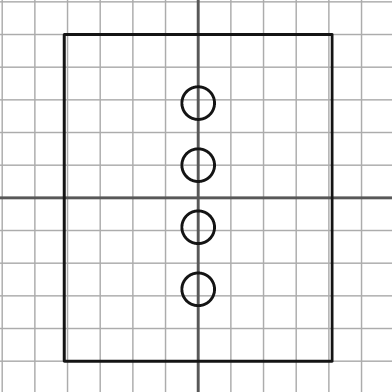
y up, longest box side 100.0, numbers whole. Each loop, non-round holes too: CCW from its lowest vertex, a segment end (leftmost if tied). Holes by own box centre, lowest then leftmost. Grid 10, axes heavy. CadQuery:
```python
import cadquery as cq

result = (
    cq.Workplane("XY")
    .moveTo(-41.0, -50.0)
    .lineTo(41.0, -50.0)
    .lineTo(41.0, 50.0)
    .lineTo(-41.0, 50.0)
    .close()
    .moveTo(0.0, -28.0)
    .circle(5.0)
    .moveTo(0.0, -9.0)
    .circle(5.0)
    .moveTo(0.0, 10.0)
    .circle(5.0)
    .moveTo(0.0, 29.0)
    .circle(5.0)
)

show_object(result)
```